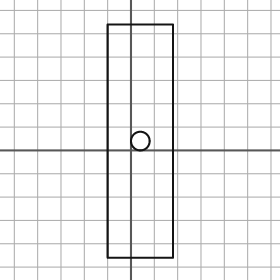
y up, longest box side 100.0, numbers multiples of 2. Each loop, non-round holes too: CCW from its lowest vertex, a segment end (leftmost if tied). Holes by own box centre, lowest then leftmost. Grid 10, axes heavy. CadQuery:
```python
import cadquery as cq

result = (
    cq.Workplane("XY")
    .moveTo(-10.0, -46.0)
    .lineTo(18.0, -46.0)
    .lineTo(18.0, 54.0)
    .lineTo(-10.0, 54.0)
    .close()
    .moveTo(4.0, 4.0)
    .circle(4.0)
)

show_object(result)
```